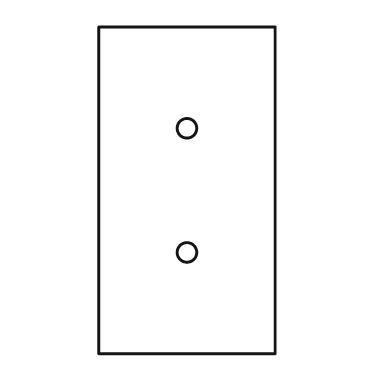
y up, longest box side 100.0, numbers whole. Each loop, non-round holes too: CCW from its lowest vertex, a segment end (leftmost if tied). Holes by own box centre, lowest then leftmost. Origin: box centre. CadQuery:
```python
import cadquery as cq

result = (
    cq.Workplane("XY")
    .moveTo(-27.0, -50.0)
    .lineTo(27.0, -50.0)
    .lineTo(27.0, 50.0)
    .lineTo(-27.0, 50.0)
    .close()
    .moveTo(0.0, -19.0)
    .circle(3.0)
    .moveTo(0.0, 19.0)
    .circle(3.0)
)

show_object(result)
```